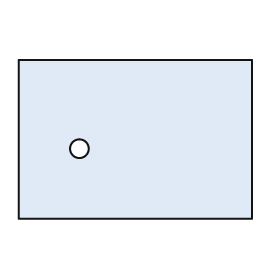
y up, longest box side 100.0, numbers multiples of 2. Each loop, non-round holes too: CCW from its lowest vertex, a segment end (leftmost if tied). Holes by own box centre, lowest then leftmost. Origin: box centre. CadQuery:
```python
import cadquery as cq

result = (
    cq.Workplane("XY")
    .moveTo(-50.0, -34.0)
    .lineTo(50.0, -34.0)
    .lineTo(50.0, 34.0)
    .lineTo(-50.0, 34.0)
    .close()
    .moveTo(-24.0, -4.0)
    .circle(4.0)
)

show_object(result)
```